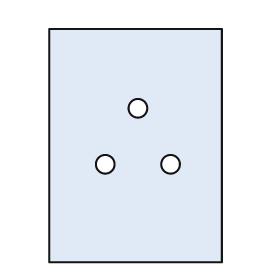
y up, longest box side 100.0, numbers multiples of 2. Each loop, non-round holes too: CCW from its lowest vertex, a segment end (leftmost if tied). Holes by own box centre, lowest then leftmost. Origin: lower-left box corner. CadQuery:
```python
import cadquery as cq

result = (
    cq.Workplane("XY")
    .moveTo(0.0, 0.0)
    .lineTo(74.0, 0.0)
    .lineTo(74.0, 100.0)
    .lineTo(0.0, 100.0)
    .close()
    .moveTo(24.0, 42.0)
    .circle(4.0)
    .moveTo(52.0, 42.0)
    .circle(4.0)
    .moveTo(38.0, 66.0)
    .circle(4.0)
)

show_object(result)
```